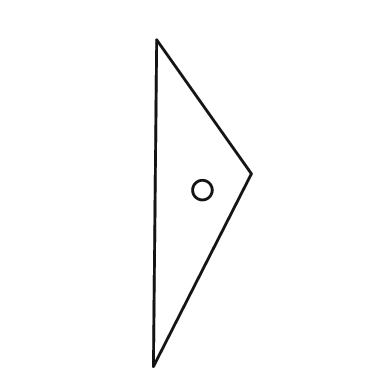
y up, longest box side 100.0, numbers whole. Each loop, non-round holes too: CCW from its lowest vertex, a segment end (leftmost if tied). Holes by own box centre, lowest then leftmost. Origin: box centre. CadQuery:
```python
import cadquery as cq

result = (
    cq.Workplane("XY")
    .moveTo(-15.0, -50.0)
    .lineTo(15.0, 9.0)
    .lineTo(-14.0, 50.0)
    .close()
    .moveTo(0.0, 4.0)
    .circle(3.0)
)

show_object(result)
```